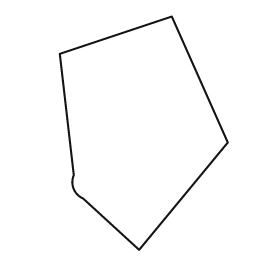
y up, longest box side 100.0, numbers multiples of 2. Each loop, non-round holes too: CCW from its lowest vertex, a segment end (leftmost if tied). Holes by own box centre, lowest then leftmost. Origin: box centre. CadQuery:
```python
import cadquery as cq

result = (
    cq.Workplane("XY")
    .moveTo(-2.0, -50.0)
    .lineTo(36.0, -4.0)
    .lineTo(12.0, 50.0)
    .lineTo(-36.0, 34.0)
    .lineTo(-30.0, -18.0)
    .threePointArc((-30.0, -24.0), (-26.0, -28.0))
    .close()
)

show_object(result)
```